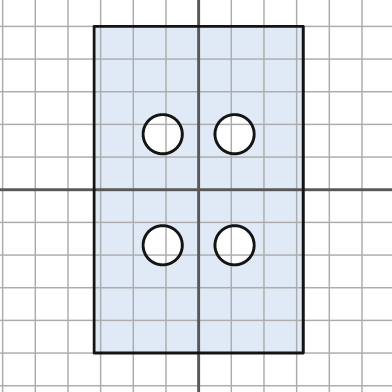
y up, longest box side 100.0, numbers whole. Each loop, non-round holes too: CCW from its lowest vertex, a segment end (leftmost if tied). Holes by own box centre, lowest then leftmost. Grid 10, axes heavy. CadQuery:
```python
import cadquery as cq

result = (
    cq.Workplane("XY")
    .moveTo(-32.0, -50.0)
    .lineTo(32.0, -50.0)
    .lineTo(32.0, 50.0)
    .lineTo(-32.0, 50.0)
    .close()
    .moveTo(-11.0, -17.0)
    .circle(6.0)
    .moveTo(11.0, -17.0)
    .circle(6.0)
    .moveTo(-11.0, 17.0)
    .circle(6.0)
    .moveTo(11.0, 17.0)
    .circle(6.0)
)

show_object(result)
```